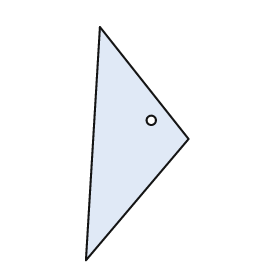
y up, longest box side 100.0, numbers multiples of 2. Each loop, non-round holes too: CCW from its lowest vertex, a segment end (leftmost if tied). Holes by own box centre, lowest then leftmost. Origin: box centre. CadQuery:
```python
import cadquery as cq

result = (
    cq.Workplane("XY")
    .moveTo(-22.0, -50.0)
    .lineTo(22.0, 2.0)
    .lineTo(-16.0, 50.0)
    .close()
    .moveTo(6.0, 10.0)
    .circle(2.0)
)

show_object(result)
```